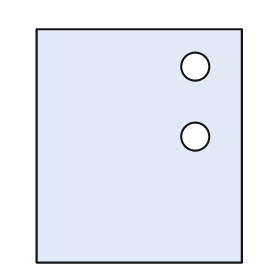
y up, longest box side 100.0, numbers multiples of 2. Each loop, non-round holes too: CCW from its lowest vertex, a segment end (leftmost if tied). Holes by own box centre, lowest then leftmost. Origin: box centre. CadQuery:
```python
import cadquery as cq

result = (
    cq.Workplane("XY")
    .moveTo(-44.0, -50.0)
    .lineTo(44.0, -50.0)
    .lineTo(44.0, 50.0)
    .lineTo(-44.0, 50.0)
    .close()
    .moveTo(24.0, 4.0)
    .circle(6.0)
    .moveTo(24.0, 34.0)
    .circle(6.0)
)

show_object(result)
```